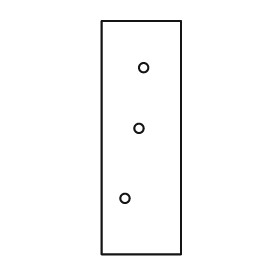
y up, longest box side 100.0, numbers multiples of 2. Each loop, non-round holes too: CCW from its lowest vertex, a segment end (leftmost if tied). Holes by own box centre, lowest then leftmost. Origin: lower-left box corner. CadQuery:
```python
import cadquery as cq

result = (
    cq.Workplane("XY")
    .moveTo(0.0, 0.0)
    .lineTo(34.0, 0.0)
    .lineTo(34.0, 100.0)
    .lineTo(0.0, 100.0)
    .close()
    .moveTo(10.0, 24.0)
    .circle(2.0)
    .moveTo(16.0, 54.0)
    .circle(2.0)
    .moveTo(18.0, 80.0)
    .circle(2.0)
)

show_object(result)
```